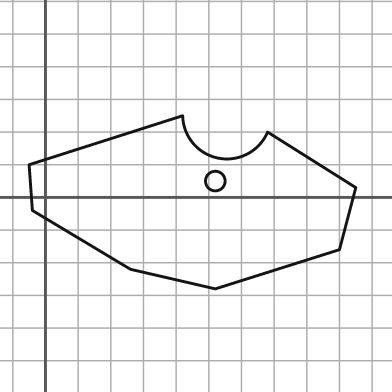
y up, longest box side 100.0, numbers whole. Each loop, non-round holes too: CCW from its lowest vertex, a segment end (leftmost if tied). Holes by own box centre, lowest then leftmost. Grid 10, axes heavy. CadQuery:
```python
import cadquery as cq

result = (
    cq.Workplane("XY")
    .moveTo(52.0, -28.0)
    .lineTo(90.0, -16.0)
    .lineTo(95.0, 3.0)
    .lineTo(68.0, 20.0)
    .threePointArc((53.0, 12.0), (42.0, 25.0))
    .lineTo(-5.0, 10.0)
    .lineTo(-4.0, -4.0)
    .lineTo(26.0, -22.0)
    .close()
    .moveTo(52.0, 5.0)
    .circle(3.0)
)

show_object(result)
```